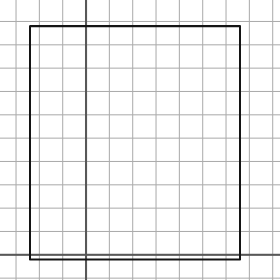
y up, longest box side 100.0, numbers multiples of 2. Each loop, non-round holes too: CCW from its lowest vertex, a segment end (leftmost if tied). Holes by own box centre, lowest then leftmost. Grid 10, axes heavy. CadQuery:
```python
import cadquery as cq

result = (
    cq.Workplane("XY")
    .moveTo(-24.0, -2.0)
    .lineTo(66.0, -2.0)
    .lineTo(66.0, 98.0)
    .lineTo(-24.0, 98.0)
    .close()
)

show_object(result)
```